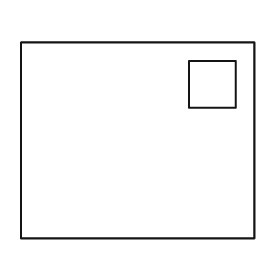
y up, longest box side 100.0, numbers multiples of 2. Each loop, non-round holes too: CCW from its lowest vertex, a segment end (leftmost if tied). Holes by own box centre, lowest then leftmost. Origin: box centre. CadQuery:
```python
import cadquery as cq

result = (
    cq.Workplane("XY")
    .moveTo(-50.0, -42.0)
    .lineTo(50.0, -42.0)
    .lineTo(50.0, 42.0)
    .lineTo(-50.0, 42.0)
    .close()
    .moveTo(22.0, 14.0)
    .lineTo(42.0, 14.0)
    .lineTo(42.0, 34.0)
    .lineTo(22.0, 34.0)
    .close()
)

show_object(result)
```